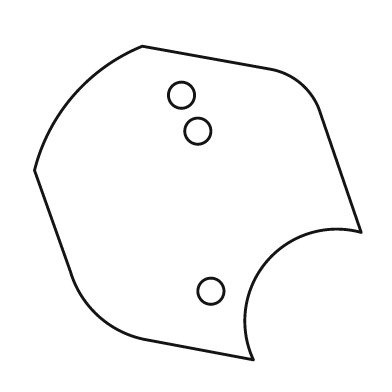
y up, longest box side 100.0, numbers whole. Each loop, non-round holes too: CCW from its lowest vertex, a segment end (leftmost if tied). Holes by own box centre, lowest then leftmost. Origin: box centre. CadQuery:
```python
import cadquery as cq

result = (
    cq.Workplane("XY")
    .moveTo(17.0, -48.0)
    .threePointArc((21.0, -18.0), (50.0, -9.0))
    .lineTo(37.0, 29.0)
    .threePointArc((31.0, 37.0), (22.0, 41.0))
    .lineTo(-17.0, 48.0)
    .threePointArc((-38.0, 33.0), (-50.0, 10.0))
    .lineTo(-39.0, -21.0)
    .threePointArc((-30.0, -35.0), (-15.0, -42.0))
    .close()
    .moveTo(4.0, -27.0)
    .circle(4.0)
    .moveTo(0.0, 22.0)
    .circle(4.0)
    .moveTo(-5.0, 33.0)
    .circle(4.0)
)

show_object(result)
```